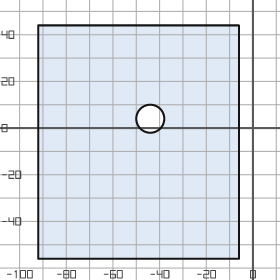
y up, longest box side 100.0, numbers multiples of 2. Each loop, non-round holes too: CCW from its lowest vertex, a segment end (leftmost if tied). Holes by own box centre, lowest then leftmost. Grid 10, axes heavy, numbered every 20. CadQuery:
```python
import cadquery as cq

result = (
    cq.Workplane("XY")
    .moveTo(-92.0, -56.0)
    .lineTo(-6.0, -56.0)
    .lineTo(-6.0, 44.0)
    .lineTo(-92.0, 44.0)
    .close()
    .moveTo(-44.0, 4.0)
    .circle(6.0)
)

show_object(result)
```